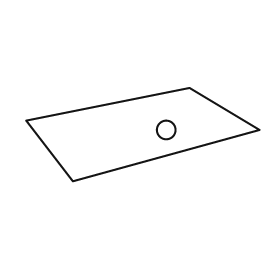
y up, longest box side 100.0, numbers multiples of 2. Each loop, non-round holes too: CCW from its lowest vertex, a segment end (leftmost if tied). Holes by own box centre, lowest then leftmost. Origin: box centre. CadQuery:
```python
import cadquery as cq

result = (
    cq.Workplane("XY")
    .moveTo(-30.0, -20.0)
    .lineTo(50.0, 2.0)
    .lineTo(20.0, 20.0)
    .lineTo(-50.0, 6.0)
    .close()
    .moveTo(10.0, 2.0)
    .circle(4.0)
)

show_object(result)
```